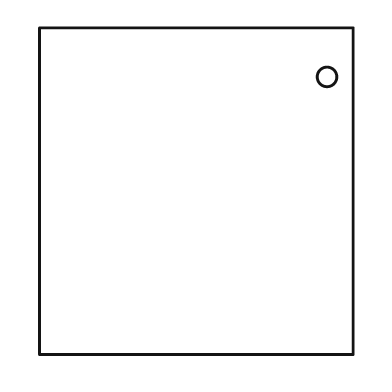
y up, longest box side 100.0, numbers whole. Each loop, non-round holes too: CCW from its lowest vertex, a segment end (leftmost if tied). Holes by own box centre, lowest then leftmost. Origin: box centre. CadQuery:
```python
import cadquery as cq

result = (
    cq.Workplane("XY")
    .moveTo(-48.0, -50.0)
    .lineTo(48.0, -50.0)
    .lineTo(48.0, 50.0)
    .lineTo(-48.0, 50.0)
    .close()
    .moveTo(40.0, 35.0)
    .circle(3.0)
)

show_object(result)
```